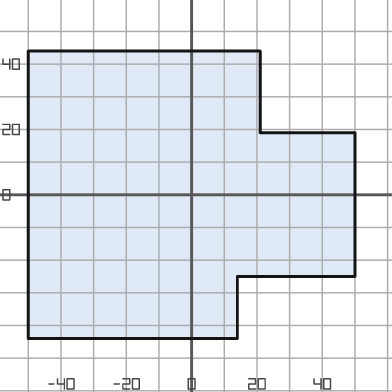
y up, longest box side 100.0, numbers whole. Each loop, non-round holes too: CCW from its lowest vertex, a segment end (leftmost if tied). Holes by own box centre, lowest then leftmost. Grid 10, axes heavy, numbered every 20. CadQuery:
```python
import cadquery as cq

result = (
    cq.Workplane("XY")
    .moveTo(-50.0, -44.0)
    .lineTo(14.0, -44.0)
    .lineTo(14.0, -25.0)
    .lineTo(50.0, -25.0)
    .lineTo(50.0, 19.0)
    .lineTo(21.0, 19.0)
    .lineTo(21.0, 44.0)
    .lineTo(-50.0, 44.0)
    .close()
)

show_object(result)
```